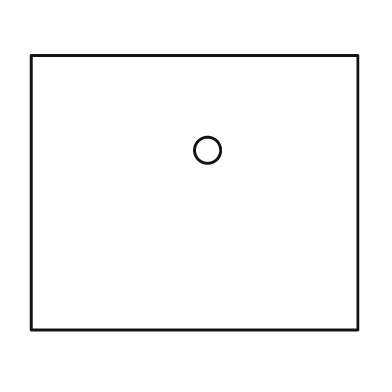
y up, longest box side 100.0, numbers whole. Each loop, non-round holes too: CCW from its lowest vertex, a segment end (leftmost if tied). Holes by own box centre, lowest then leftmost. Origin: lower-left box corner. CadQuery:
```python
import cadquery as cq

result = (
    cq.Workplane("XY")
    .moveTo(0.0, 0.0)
    .lineTo(100.0, 0.0)
    .lineTo(100.0, 84.0)
    .lineTo(0.0, 84.0)
    .close()
    .moveTo(54.0, 55.0)
    .circle(4.0)
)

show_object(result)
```